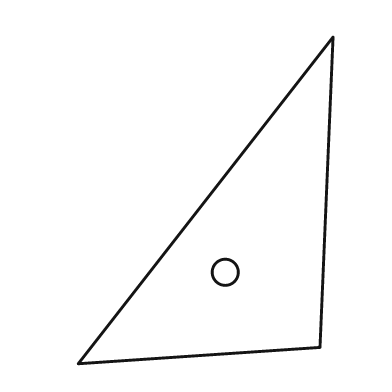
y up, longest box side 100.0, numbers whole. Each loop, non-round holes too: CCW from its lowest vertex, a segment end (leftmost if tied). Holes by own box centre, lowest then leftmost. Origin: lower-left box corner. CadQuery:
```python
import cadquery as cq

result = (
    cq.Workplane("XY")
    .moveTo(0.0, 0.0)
    .lineTo(74.0, 5.0)
    .lineTo(78.0, 100.0)
    .close()
    .moveTo(45.0, 28.0)
    .circle(4.0)
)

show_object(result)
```